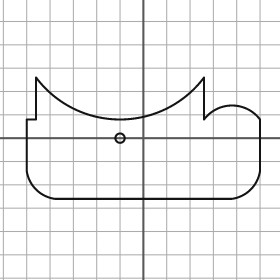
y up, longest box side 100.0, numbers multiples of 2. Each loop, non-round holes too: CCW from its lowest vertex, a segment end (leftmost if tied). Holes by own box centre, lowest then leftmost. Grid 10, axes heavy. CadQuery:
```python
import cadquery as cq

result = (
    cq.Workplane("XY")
    .moveTo(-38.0, -26.0)
    .lineTo(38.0, -26.0)
    .threePointArc((46.0, -22.0), (50.0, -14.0))
    .lineTo(50.0, 8.0)
    .threePointArc((38.0, 14.0), (26.0, 8.0))
    .lineTo(26.0, 26.0)
    .threePointArc((-10.0, 8.0), (-46.0, 26.0))
    .lineTo(-46.0, 8.0)
    .lineTo(-50.0, 8.0)
    .lineTo(-50.0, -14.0)
    .threePointArc((-46.0, -22.0), (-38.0, -26.0))
    .close()
    .moveTo(-10.0, 0.0)
    .circle(2.0)
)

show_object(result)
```